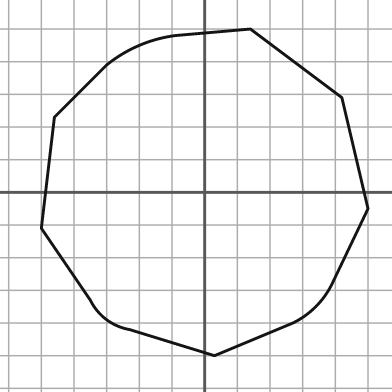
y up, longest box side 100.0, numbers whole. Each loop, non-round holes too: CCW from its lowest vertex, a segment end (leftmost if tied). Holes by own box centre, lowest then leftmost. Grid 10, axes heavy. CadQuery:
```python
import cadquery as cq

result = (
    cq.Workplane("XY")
    .moveTo(3.0, -50.0)
    .lineTo(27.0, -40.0)
    .threePointArc((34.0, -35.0), (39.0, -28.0))
    .lineTo(50.0, -5.0)
    .lineTo(42.0, 29.0)
    .lineTo(14.0, 50.0)
    .lineTo(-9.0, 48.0)
    .threePointArc((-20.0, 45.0), (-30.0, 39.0))
    .lineTo(-46.0, 23.0)
    .lineTo(-50.0, -11.0)
    .lineTo(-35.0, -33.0)
    .threePointArc((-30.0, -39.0), (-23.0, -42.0))
    .close()
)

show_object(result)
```